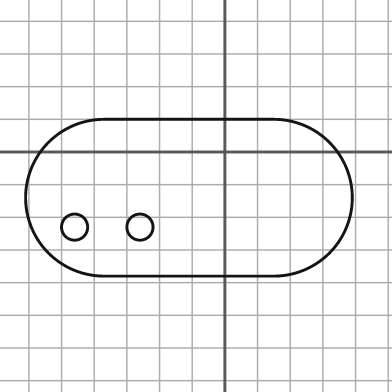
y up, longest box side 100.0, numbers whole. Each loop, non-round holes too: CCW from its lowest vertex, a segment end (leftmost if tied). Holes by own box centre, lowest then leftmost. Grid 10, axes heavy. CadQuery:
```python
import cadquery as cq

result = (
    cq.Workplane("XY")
    .moveTo(-37.0, -38.0)
    .lineTo(15.0, -38.0)
    .threePointArc((39.0, -14.0), (15.0, 10.0))
    .lineTo(-37.0, 10.0)
    .threePointArc((-61.0, -14.0), (-37.0, -38.0))
    .close()
    .moveTo(-46.0, -23.0)
    .circle(4.0)
    .moveTo(-26.0, -23.0)
    .circle(4.0)
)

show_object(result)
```